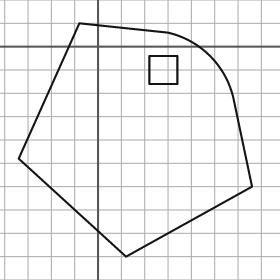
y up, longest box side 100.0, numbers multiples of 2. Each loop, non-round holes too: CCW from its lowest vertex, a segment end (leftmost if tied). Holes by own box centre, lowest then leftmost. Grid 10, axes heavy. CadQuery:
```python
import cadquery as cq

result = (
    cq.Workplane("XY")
    .moveTo(12.0, -90.0)
    .lineTo(66.0, -60.0)
    .lineTo(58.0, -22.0)
    .threePointArc((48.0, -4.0), (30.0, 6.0))
    .lineTo(-8.0, 10.0)
    .lineTo(-34.0, -48.0)
    .close()
    .moveTo(22.0, -16.0)
    .lineTo(34.0, -16.0)
    .lineTo(34.0, -4.0)
    .lineTo(22.0, -4.0)
    .close()
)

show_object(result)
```